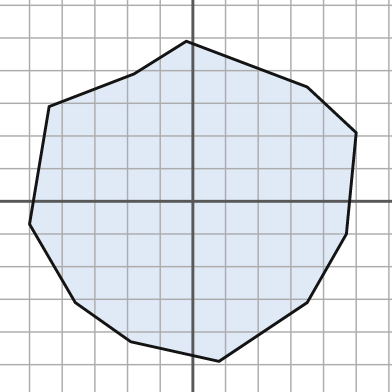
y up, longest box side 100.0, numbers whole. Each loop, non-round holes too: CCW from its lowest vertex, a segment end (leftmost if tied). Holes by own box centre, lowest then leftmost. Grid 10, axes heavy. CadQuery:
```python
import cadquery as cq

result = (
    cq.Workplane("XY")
    .moveTo(8.0, -49.0)
    .lineTo(35.0, -31.0)
    .lineTo(47.0, -10.0)
    .lineTo(50.0, 21.0)
    .lineTo(35.0, 35.0)
    .lineTo(-2.0, 49.0)
    .lineTo(-18.0, 39.0)
    .lineTo(-44.0, 29.0)
    .lineTo(-50.0, -7.0)
    .lineTo(-36.0, -31.0)
    .lineTo(-19.0, -43.0)
    .close()
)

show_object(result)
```